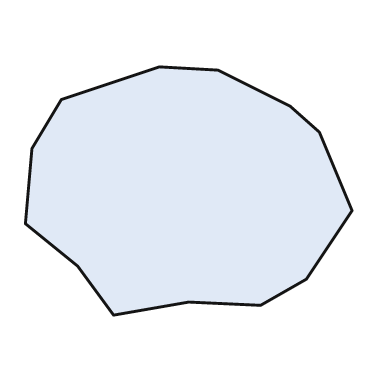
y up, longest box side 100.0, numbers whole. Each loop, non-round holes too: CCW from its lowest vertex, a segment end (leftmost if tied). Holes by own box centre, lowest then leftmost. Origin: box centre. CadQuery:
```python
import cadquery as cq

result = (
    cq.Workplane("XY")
    .moveTo(-23.0, -38.0)
    .lineTo(0.0, -34.0)
    .lineTo(22.0, -35.0)
    .lineTo(36.0, -27.0)
    .lineTo(50.0, -6.0)
    .lineTo(40.0, 18.0)
    .lineTo(31.0, 26.0)
    .lineTo(9.0, 37.0)
    .lineTo(-9.0, 38.0)
    .lineTo(-39.0, 28.0)
    .lineTo(-48.0, 13.0)
    .lineTo(-50.0, -10.0)
    .lineTo(-34.0, -23.0)
    .close()
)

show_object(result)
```